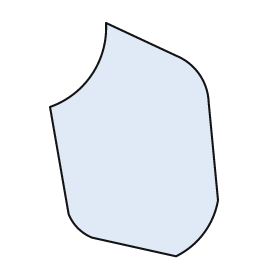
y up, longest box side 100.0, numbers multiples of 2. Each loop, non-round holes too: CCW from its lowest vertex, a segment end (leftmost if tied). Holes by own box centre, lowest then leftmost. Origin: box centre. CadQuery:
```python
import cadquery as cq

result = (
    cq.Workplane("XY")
    .moveTo(18.0, -50.0)
    .threePointArc((30.0, -40.0), (36.0, -26.0))
    .lineTo(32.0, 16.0)
    .threePointArc((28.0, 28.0), (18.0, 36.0))
    .lineTo(-12.0, 50.0)
    .threePointArc((-18.0, 28.0), (-36.0, 14.0))
    .lineTo(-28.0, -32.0)
    .threePointArc((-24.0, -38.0), (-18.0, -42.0))
    .close()
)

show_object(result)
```